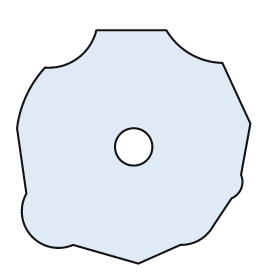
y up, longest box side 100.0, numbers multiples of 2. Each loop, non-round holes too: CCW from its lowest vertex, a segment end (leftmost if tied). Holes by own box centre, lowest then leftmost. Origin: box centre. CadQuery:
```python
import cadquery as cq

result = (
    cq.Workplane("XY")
    .moveTo(2.0, -50.0)
    .lineTo(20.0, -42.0)
    .threePointArc((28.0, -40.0), (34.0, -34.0))
    .lineTo(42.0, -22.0)
    .threePointArc((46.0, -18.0), (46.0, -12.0))
    .lineTo(50.0, 10.0)
    .lineTo(38.0, 36.0)
    .threePointArc((24.0, 40.0), (14.0, 50.0))
    .lineTo(-16.0, 50.0)
    .threePointArc((-24.0, 38.0), (-38.0, 34.0))
    .threePointArc((-46.0, 22.0), (-50.0, 8.0))
    .lineTo(-46.0, -20.0)
    .threePointArc((-44.0, -38.0), (-26.0, -42.0))
    .close()
    .moveTo(0.0, 0.0)
    .circle(8.0)
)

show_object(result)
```